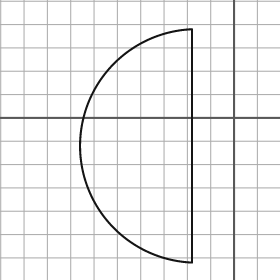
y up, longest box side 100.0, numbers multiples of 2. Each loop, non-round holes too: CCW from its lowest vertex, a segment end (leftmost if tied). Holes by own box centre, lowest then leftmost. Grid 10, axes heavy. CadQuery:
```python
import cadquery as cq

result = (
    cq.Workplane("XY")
    .moveTo(-18.0, -62.0)
    .lineTo(-18.0, 38.0)
    .threePointArc((-66.0, -12.0), (-18.0, -62.0))
    .close()
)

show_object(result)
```